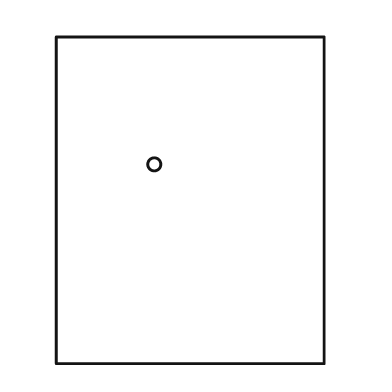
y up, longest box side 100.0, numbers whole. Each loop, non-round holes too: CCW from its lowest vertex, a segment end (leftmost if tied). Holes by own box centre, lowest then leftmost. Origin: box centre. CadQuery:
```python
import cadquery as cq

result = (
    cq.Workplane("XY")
    .moveTo(-41.0, -50.0)
    .lineTo(41.0, -50.0)
    .lineTo(41.0, 50.0)
    .lineTo(-41.0, 50.0)
    .close()
    .moveTo(-11.0, 11.0)
    .circle(2.0)
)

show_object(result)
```